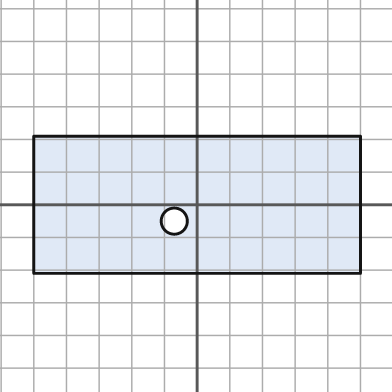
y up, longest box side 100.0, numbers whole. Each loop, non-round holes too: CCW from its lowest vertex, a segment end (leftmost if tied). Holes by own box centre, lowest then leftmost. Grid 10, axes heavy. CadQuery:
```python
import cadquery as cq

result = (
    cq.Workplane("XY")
    .moveTo(-50.0, -21.0)
    .lineTo(50.0, -21.0)
    .lineTo(50.0, 21.0)
    .lineTo(-50.0, 21.0)
    .close()
    .moveTo(-7.0, -5.0)
    .circle(4.0)
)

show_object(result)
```